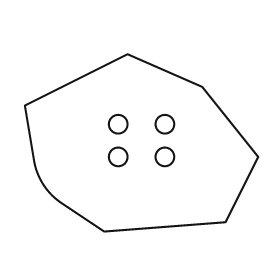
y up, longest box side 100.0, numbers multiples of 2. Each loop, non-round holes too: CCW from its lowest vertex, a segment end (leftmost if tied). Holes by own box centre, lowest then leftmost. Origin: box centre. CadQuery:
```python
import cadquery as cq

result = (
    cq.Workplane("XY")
    .moveTo(-16.0, -38.0)
    .lineTo(36.0, -34.0)
    .lineTo(50.0, -6.0)
    .lineTo(26.0, 24.0)
    .lineTo(-6.0, 38.0)
    .lineTo(-50.0, 16.0)
    .lineTo(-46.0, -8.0)
    .threePointArc((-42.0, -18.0), (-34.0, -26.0))
    .close()
    .moveTo(-10.0, -6.0)
    .circle(4.0)
    .moveTo(10.0, -6.0)
    .circle(4.0)
    .moveTo(-10.0, 8.0)
    .circle(4.0)
    .moveTo(10.0, 8.0)
    .circle(4.0)
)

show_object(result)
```